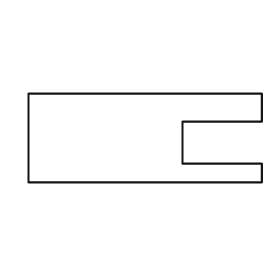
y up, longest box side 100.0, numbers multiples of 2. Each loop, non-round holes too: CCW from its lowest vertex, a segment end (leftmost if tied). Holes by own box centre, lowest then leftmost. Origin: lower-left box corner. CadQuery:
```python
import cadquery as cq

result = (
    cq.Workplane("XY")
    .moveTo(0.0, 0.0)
    .lineTo(100.0, 0.0)
    .lineTo(100.0, 8.0)
    .lineTo(66.0, 8.0)
    .lineTo(66.0, 26.0)
    .lineTo(100.0, 26.0)
    .lineTo(100.0, 38.0)
    .lineTo(0.0, 38.0)
    .close()
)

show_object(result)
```